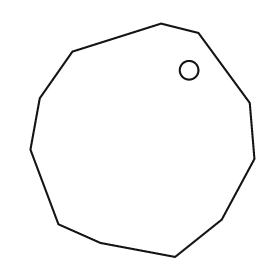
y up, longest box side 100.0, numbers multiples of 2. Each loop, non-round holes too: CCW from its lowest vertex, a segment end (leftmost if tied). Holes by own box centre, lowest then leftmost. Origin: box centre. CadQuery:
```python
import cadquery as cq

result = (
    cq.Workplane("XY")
    .moveTo(14.0, -50.0)
    .lineTo(34.0, -34.0)
    .lineTo(48.0, -8.0)
    .lineTo(46.0, 16.0)
    .lineTo(24.0, 46.0)
    .lineTo(8.0, 50.0)
    .lineTo(-30.0, 38.0)
    .lineTo(-44.0, 18.0)
    .lineTo(-48.0, -4.0)
    .lineTo(-36.0, -36.0)
    .lineTo(-18.0, -44.0)
    .close()
    .moveTo(20.0, 30.0)
    .circle(4.0)
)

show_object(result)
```